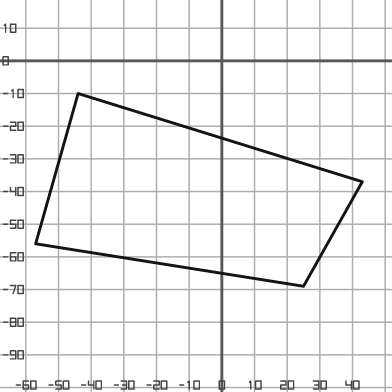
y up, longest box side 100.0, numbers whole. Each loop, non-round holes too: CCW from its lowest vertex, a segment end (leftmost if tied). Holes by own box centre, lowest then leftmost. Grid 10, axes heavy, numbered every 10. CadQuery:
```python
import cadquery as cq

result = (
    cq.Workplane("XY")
    .moveTo(25.0, -69.0)
    .lineTo(43.0, -37.0)
    .lineTo(-44.0, -10.0)
    .lineTo(-57.0, -56.0)
    .close()
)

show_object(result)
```